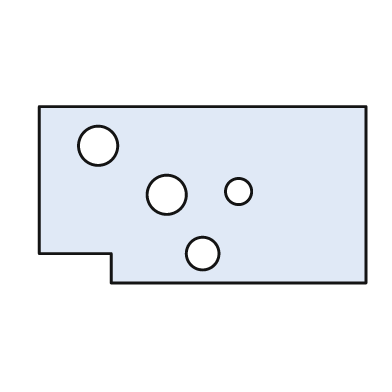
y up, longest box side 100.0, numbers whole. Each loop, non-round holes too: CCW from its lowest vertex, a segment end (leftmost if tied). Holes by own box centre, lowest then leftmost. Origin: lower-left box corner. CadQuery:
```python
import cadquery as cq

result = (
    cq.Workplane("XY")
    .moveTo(22.0, 0.0)
    .lineTo(100.0, 0.0)
    .lineTo(100.0, 54.0)
    .lineTo(0.0, 54.0)
    .lineTo(0.0, 9.0)
    .lineTo(22.0, 9.0)
    .close()
    .moveTo(50.0, 9.0)
    .circle(5.0)
    .moveTo(39.0, 27.0)
    .circle(6.0)
    .moveTo(61.0, 28.0)
    .circle(4.0)
    .moveTo(18.0, 42.0)
    .circle(6.0)
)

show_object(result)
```